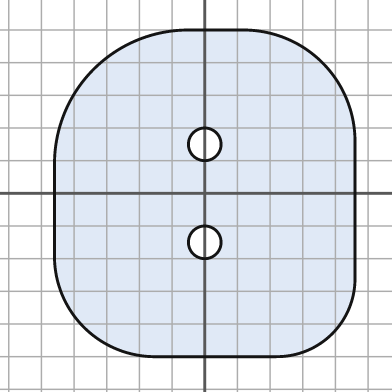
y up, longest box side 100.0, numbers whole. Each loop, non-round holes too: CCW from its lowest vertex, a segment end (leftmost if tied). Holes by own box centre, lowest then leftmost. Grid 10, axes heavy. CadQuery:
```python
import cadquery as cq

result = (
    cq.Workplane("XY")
    .moveTo(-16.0, -50.0)
    .lineTo(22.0, -50.0)
    .threePointArc((39.0, -43.0), (46.0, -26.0))
    .lineTo(46.0, 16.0)
    .threePointArc((36.0, 40.0), (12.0, 50.0))
    .lineTo(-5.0, 50.0)
    .threePointArc((-34.0, 38.0), (-46.0, 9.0))
    .lineTo(-46.0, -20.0)
    .threePointArc((-37.0, -41.0), (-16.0, -50.0))
    .close()
    .moveTo(0.0, -15.0)
    .circle(5.0)
    .moveTo(0.0, 15.0)
    .circle(5.0)
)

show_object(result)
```